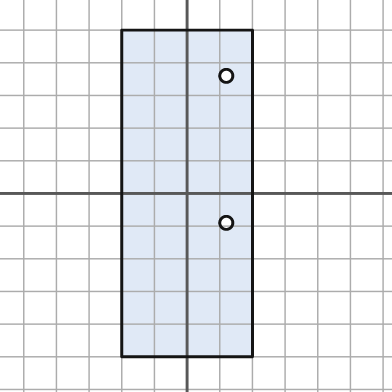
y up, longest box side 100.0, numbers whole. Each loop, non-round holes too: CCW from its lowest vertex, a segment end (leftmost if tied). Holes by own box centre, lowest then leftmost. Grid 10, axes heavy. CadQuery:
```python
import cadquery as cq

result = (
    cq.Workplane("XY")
    .moveTo(-20.0, -50.0)
    .lineTo(20.0, -50.0)
    .lineTo(20.0, 50.0)
    .lineTo(-20.0, 50.0)
    .close()
    .moveTo(12.0, -9.0)
    .circle(2.0)
    .moveTo(12.0, 36.0)
    .circle(2.0)
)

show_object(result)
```